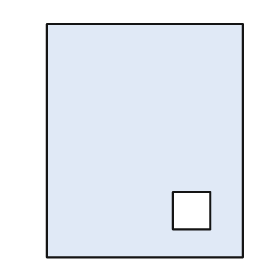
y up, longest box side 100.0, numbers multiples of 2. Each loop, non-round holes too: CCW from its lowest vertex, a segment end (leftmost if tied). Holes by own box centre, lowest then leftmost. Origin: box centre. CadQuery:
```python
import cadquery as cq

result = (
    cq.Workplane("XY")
    .moveTo(-42.0, -50.0)
    .lineTo(42.0, -50.0)
    .lineTo(42.0, 50.0)
    .lineTo(-42.0, 50.0)
    .close()
    .moveTo(12.0, -38.0)
    .lineTo(28.0, -38.0)
    .lineTo(28.0, -22.0)
    .lineTo(12.0, -22.0)
    .close()
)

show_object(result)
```